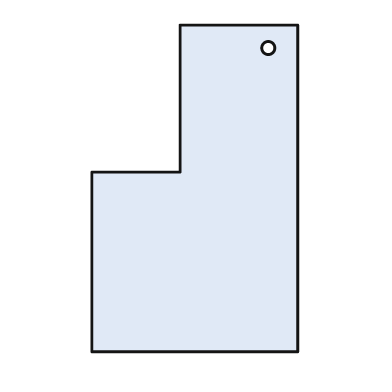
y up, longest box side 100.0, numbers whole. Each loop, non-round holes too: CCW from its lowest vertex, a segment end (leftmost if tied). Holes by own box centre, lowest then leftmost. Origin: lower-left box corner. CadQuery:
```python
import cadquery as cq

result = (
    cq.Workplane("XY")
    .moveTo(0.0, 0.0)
    .lineTo(63.0, 0.0)
    .lineTo(63.0, 100.0)
    .lineTo(27.0, 100.0)
    .lineTo(27.0, 55.0)
    .lineTo(0.0, 55.0)
    .close()
    .moveTo(54.0, 93.0)
    .circle(2.0)
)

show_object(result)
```